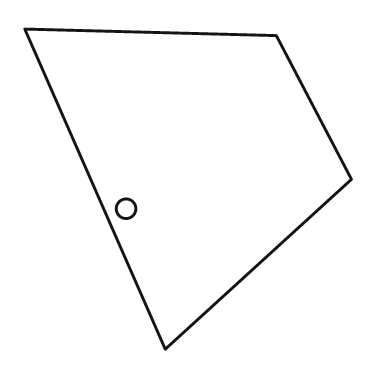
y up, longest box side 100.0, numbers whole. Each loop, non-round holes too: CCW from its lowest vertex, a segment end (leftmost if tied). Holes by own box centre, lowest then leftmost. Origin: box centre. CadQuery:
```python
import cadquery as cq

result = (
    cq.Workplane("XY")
    .moveTo(-7.0, -49.0)
    .lineTo(50.0, 3.0)
    .lineTo(27.0, 47.0)
    .lineTo(-50.0, 49.0)
    .close()
    .moveTo(-19.0, -6.0)
    .circle(3.0)
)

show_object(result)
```